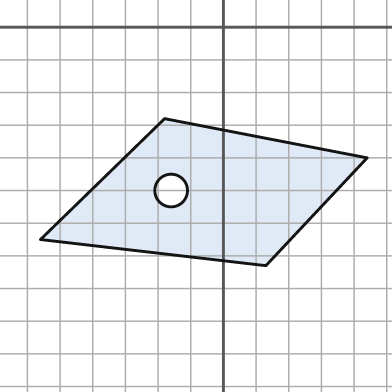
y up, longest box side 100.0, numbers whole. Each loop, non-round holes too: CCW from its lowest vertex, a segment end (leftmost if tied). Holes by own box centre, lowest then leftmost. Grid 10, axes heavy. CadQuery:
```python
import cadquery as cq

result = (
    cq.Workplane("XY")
    .moveTo(13.0, -73.0)
    .lineTo(44.0, -40.0)
    .lineTo(-18.0, -28.0)
    .lineTo(-56.0, -65.0)
    .close()
    .moveTo(-16.0, -50.0)
    .circle(5.0)
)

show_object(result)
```